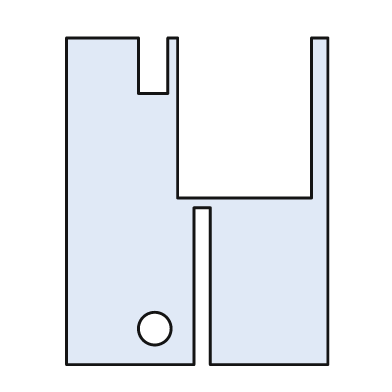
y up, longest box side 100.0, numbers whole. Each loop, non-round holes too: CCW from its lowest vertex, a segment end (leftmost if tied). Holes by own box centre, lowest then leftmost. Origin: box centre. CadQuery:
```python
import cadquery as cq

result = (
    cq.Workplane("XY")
    .moveTo(-40.0, -50.0)
    .lineTo(-1.0, -50.0)
    .lineTo(-1.0, -2.0)
    .lineTo(4.0, -2.0)
    .lineTo(4.0, -50.0)
    .lineTo(40.0, -50.0)
    .lineTo(40.0, 50.0)
    .lineTo(35.0, 50.0)
    .lineTo(35.0, 1.0)
    .lineTo(-6.0, 1.0)
    .lineTo(-6.0, 50.0)
    .lineTo(-9.0, 50.0)
    .lineTo(-9.0, 33.0)
    .lineTo(-18.0, 33.0)
    .lineTo(-18.0, 50.0)
    .lineTo(-40.0, 50.0)
    .close()
    .moveTo(-13.0, -39.0)
    .circle(5.0)
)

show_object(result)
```